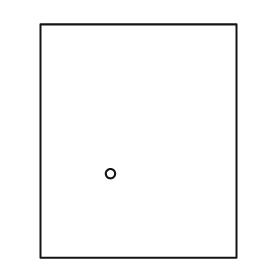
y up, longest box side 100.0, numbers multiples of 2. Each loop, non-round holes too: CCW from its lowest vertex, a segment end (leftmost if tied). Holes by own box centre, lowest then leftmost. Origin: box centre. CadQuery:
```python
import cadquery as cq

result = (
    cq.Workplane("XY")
    .moveTo(-42.0, -50.0)
    .lineTo(42.0, -50.0)
    .lineTo(42.0, 50.0)
    .lineTo(-42.0, 50.0)
    .close()
    .moveTo(-12.0, -14.0)
    .circle(2.0)
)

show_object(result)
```